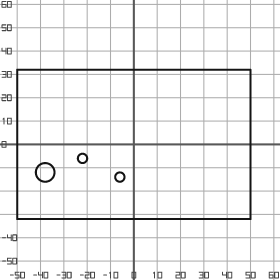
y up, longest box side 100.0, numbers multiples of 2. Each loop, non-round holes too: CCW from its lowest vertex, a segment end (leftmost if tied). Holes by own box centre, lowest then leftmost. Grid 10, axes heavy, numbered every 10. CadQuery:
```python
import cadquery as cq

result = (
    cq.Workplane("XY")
    .moveTo(-50.0, -32.0)
    .lineTo(50.0, -32.0)
    .lineTo(50.0, 32.0)
    .lineTo(-50.0, 32.0)
    .close()
    .moveTo(-6.0, -14.0)
    .circle(2.0)
    .moveTo(-38.0, -12.0)
    .circle(4.0)
    .moveTo(-22.0, -6.0)
    .circle(2.0)
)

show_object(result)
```